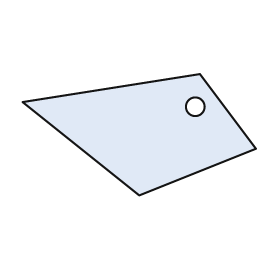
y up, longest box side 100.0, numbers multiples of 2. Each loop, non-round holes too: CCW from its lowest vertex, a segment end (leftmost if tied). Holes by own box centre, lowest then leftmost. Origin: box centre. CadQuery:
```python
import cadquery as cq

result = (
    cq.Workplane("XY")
    .moveTo(0.0, -26.0)
    .lineTo(50.0, -6.0)
    .lineTo(26.0, 26.0)
    .lineTo(-50.0, 14.0)
    .close()
    .moveTo(24.0, 12.0)
    .circle(4.0)
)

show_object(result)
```